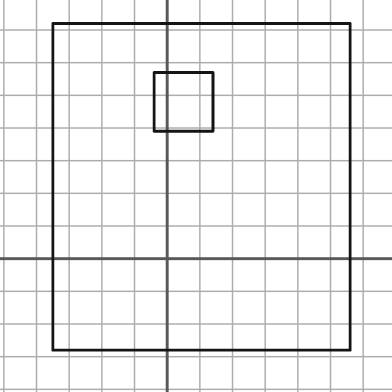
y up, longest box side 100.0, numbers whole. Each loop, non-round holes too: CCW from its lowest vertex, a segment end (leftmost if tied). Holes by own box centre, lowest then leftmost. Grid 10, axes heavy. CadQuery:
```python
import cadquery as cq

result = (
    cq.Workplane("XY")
    .moveTo(-35.0, -28.0)
    .lineTo(56.0, -28.0)
    .lineTo(56.0, 72.0)
    .lineTo(-35.0, 72.0)
    .close()
    .moveTo(-4.0, 39.0)
    .lineTo(14.0, 39.0)
    .lineTo(14.0, 57.0)
    .lineTo(-4.0, 57.0)
    .close()
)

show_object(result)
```